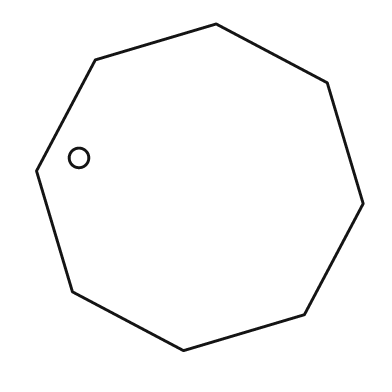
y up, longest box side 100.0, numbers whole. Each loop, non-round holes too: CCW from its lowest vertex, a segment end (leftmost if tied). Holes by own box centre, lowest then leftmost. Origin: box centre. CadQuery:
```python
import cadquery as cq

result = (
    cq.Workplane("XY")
    .moveTo(-5.0, -50.0)
    .lineTo(32.0, -39.0)
    .lineTo(50.0, -5.0)
    .lineTo(39.0, 32.0)
    .lineTo(5.0, 50.0)
    .lineTo(-32.0, 39.0)
    .lineTo(-50.0, 5.0)
    .lineTo(-39.0, -32.0)
    .close()
    .moveTo(-37.0, 9.0)
    .circle(3.0)
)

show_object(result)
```